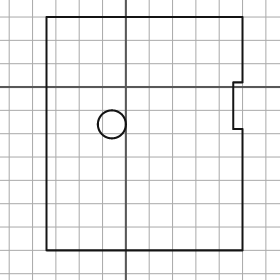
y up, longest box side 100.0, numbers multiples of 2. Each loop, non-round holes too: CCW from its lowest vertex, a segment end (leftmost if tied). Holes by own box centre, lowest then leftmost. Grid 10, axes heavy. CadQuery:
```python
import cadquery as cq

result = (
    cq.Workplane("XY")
    .moveTo(-34.0, -70.0)
    .lineTo(50.0, -70.0)
    .lineTo(50.0, -18.0)
    .lineTo(46.0, -18.0)
    .lineTo(46.0, 2.0)
    .lineTo(50.0, 2.0)
    .lineTo(50.0, 30.0)
    .lineTo(-34.0, 30.0)
    .close()
    .moveTo(-6.0, -16.0)
    .circle(6.0)
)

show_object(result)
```